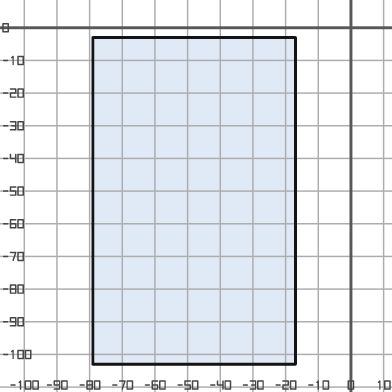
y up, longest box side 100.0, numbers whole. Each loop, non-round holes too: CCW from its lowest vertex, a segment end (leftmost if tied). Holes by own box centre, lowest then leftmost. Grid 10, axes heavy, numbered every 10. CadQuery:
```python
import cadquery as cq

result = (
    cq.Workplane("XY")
    .moveTo(-79.0, -103.0)
    .lineTo(-17.0, -103.0)
    .lineTo(-17.0, -3.0)
    .lineTo(-79.0, -3.0)
    .close()
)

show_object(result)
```